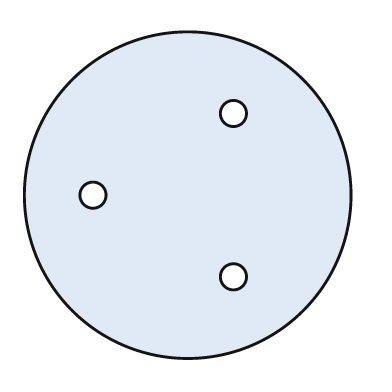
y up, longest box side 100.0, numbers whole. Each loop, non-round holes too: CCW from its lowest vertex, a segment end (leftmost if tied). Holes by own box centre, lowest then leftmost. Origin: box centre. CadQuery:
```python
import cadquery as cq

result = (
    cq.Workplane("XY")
    .moveTo(0.0, 0.0)
    .circle(50.0)
    .moveTo(14.0, -25.0)
    .circle(4.0)
    .moveTo(-29.0, 0.0)
    .circle(4.0)
    .moveTo(14.0, 25.0)
    .circle(4.0)
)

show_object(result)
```